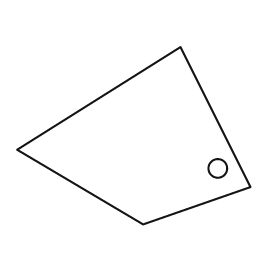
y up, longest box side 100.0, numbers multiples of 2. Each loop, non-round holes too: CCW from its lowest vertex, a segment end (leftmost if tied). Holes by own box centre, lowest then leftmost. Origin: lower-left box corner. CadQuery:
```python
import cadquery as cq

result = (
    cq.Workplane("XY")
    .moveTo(54.0, 0.0)
    .lineTo(100.0, 16.0)
    .lineTo(70.0, 76.0)
    .lineTo(0.0, 32.0)
    .close()
    .moveTo(86.0, 24.0)
    .circle(4.0)
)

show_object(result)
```